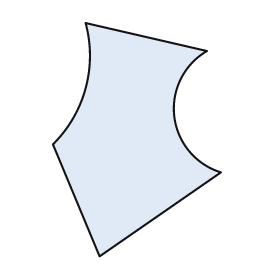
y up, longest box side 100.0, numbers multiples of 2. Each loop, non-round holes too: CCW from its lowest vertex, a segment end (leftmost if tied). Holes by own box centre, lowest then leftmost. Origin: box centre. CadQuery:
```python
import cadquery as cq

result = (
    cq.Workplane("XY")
    .moveTo(-16.0, -50.0)
    .lineTo(36.0, -14.0)
    .threePointArc((16.0, 10.0), (30.0, 38.0))
    .lineTo(-22.0, 50.0)
    .threePointArc((-22.0, 22.0), (-36.0, -2.0))
    .close()
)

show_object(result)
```